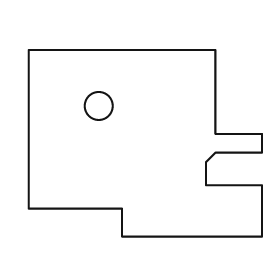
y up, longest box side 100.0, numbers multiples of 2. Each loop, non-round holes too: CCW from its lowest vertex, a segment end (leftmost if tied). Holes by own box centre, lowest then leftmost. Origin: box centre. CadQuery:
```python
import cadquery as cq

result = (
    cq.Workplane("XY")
    .moveTo(-10.0, -40.0)
    .lineTo(50.0, -40.0)
    .lineTo(50.0, -18.0)
    .lineTo(26.0, -18.0)
    .lineTo(26.0, -8.0)
    .lineTo(30.0, -4.0)
    .lineTo(50.0, -4.0)
    .lineTo(50.0, 4.0)
    .lineTo(30.0, 4.0)
    .lineTo(30.0, 40.0)
    .lineTo(-50.0, 40.0)
    .lineTo(-50.0, -28.0)
    .lineTo(-10.0, -28.0)
    .close()
    .moveTo(-20.0, 16.0)
    .circle(6.0)
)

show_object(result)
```